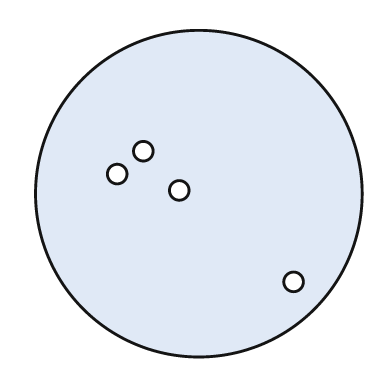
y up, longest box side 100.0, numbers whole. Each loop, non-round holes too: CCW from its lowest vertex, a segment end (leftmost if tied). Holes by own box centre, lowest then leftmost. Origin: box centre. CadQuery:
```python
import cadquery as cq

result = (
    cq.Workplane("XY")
    .moveTo(0.0, 0.0)
    .circle(50.0)
    .moveTo(29.0, -27.0)
    .circle(3.0)
    .moveTo(-6.0, 1.0)
    .circle(3.0)
    .moveTo(-25.0, 6.0)
    .circle(3.0)
    .moveTo(-17.0, 13.0)
    .circle(3.0)
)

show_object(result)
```